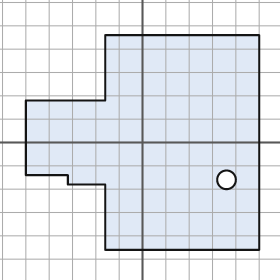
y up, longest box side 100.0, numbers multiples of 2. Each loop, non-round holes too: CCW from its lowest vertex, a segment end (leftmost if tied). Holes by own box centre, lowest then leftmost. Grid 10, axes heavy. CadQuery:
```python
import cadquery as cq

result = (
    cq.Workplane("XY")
    .moveTo(-16.0, -46.0)
    .lineTo(50.0, -46.0)
    .lineTo(50.0, 46.0)
    .lineTo(-16.0, 46.0)
    .lineTo(-16.0, 18.0)
    .lineTo(-50.0, 18.0)
    .lineTo(-50.0, -14.0)
    .lineTo(-32.0, -14.0)
    .lineTo(-32.0, -18.0)
    .lineTo(-16.0, -18.0)
    .close()
    .moveTo(36.0, -16.0)
    .circle(4.0)
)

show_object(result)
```